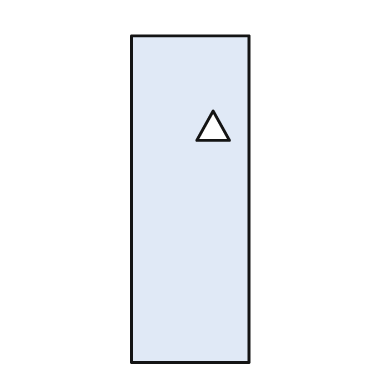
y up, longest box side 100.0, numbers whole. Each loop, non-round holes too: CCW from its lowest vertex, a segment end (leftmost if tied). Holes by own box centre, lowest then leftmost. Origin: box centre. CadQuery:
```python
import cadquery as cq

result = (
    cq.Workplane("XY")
    .moveTo(-18.0, -50.0)
    .lineTo(18.0, -50.0)
    .lineTo(18.0, 50.0)
    .lineTo(-18.0, 50.0)
    .close()
    .moveTo(2.0, 18.0)
    .lineTo(12.0, 18.0)
    .lineTo(7.0, 27.0)
    .close()
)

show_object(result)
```